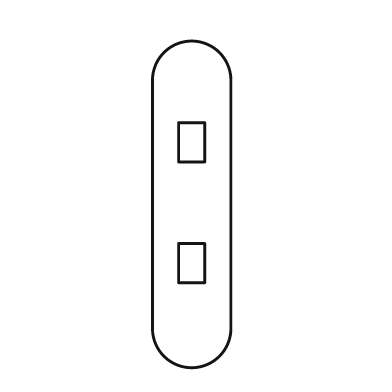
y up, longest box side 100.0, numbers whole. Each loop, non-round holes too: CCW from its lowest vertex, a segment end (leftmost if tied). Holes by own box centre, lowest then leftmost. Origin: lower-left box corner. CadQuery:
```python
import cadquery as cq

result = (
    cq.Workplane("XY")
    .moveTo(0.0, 12.0)
    .threePointArc((12.0, 0.0), (24.0, 12.0))
    .lineTo(24.0, 88.0)
    .threePointArc((12.0, 100.0), (0.0, 88.0))
    .close()
    .moveTo(8.0, 26.0)
    .lineTo(16.0, 26.0)
    .lineTo(16.0, 38.0)
    .lineTo(8.0, 38.0)
    .close()
    .moveTo(8.0, 63.0)
    .lineTo(16.0, 63.0)
    .lineTo(16.0, 75.0)
    .lineTo(8.0, 75.0)
    .close()
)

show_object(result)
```